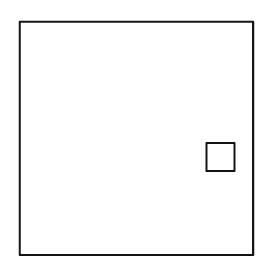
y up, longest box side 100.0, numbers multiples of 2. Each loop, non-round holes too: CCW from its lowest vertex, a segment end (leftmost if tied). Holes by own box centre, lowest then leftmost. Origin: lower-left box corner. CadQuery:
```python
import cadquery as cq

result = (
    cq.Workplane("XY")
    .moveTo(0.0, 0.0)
    .lineTo(100.0, 0.0)
    .lineTo(100.0, 100.0)
    .lineTo(0.0, 100.0)
    .close()
    .moveTo(80.0, 36.0)
    .lineTo(92.0, 36.0)
    .lineTo(92.0, 48.0)
    .lineTo(80.0, 48.0)
    .close()
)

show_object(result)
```